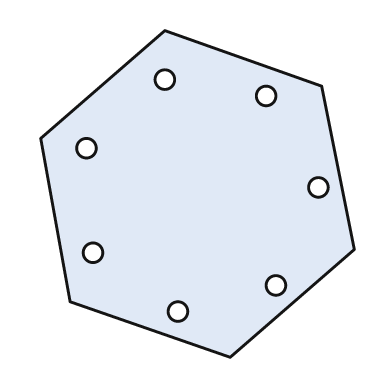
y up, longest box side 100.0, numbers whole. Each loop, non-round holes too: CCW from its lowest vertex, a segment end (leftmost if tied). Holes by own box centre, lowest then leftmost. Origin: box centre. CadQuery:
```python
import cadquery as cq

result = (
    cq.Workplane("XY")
    .moveTo(10.0, -50.0)
    .lineTo(48.0, -17.0)
    .lineTo(38.0, 33.0)
    .lineTo(-10.0, 50.0)
    .lineTo(-48.0, 17.0)
    .lineTo(-39.0, -33.0)
    .close()
    .moveTo(-6.0, -36.0)
    .circle(3.0)
    .moveTo(24.0, -28.0)
    .circle(3.0)
    .moveTo(-32.0, -18.0)
    .circle(3.0)
    .moveTo(37.0, 2.0)
    .circle(3.0)
    .moveTo(-34.0, 14.0)
    .circle(3.0)
    .moveTo(21.0, 30.0)
    .circle(3.0)
    .moveTo(-10.0, 35.0)
    .circle(3.0)
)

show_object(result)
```